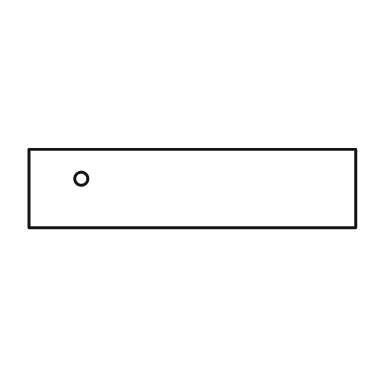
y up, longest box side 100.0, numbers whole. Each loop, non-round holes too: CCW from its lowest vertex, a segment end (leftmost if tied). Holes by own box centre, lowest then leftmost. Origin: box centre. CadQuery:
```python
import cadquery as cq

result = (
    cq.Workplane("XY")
    .moveTo(-50.0, -12.0)
    .lineTo(50.0, -12.0)
    .lineTo(50.0, 12.0)
    .lineTo(-50.0, 12.0)
    .close()
    .moveTo(-34.0, 3.0)
    .circle(2.0)
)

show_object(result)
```